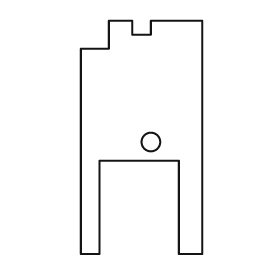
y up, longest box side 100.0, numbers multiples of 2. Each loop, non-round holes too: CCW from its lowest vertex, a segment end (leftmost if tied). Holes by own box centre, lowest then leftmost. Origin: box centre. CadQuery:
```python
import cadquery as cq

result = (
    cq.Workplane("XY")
    .moveTo(-26.0, -50.0)
    .lineTo(-18.0, -50.0)
    .lineTo(-18.0, -10.0)
    .lineTo(16.0, -10.0)
    .lineTo(16.0, -50.0)
    .lineTo(26.0, -50.0)
    .lineTo(26.0, 50.0)
    .lineTo(4.0, 50.0)
    .lineTo(4.0, 44.0)
    .lineTo(-4.0, 44.0)
    .lineTo(-4.0, 50.0)
    .lineTo(-14.0, 50.0)
    .lineTo(-14.0, 38.0)
    .lineTo(-26.0, 38.0)
    .close()
    .moveTo(4.0, -2.0)
    .circle(4.0)
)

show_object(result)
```